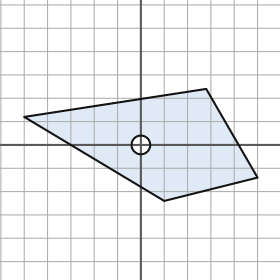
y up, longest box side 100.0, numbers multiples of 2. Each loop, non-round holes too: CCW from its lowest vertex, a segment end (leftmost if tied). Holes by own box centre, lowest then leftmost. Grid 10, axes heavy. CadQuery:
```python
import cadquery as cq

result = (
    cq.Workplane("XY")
    .moveTo(10.0, -24.0)
    .lineTo(50.0, -14.0)
    .lineTo(28.0, 24.0)
    .lineTo(-50.0, 12.0)
    .close()
    .moveTo(0.0, 0.0)
    .circle(4.0)
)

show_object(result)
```